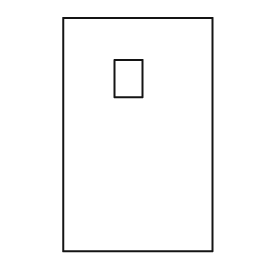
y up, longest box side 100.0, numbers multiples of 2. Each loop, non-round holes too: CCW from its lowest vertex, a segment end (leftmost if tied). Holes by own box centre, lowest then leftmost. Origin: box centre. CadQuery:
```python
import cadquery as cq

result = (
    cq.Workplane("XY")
    .moveTo(-32.0, -50.0)
    .lineTo(32.0, -50.0)
    .lineTo(32.0, 50.0)
    .lineTo(-32.0, 50.0)
    .close()
    .moveTo(-10.0, 16.0)
    .lineTo(2.0, 16.0)
    .lineTo(2.0, 32.0)
    .lineTo(-10.0, 32.0)
    .close()
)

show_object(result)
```